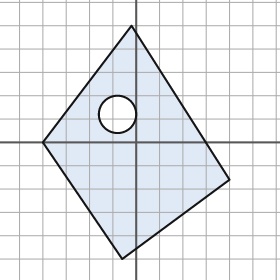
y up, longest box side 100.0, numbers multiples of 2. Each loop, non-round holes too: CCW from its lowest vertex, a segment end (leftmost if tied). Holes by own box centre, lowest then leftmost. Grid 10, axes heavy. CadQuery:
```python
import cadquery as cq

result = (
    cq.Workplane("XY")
    .moveTo(-6.0, -50.0)
    .lineTo(40.0, -16.0)
    .lineTo(-2.0, 50.0)
    .lineTo(-40.0, 0.0)
    .close()
    .moveTo(-8.0, 12.0)
    .circle(8.0)
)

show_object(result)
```